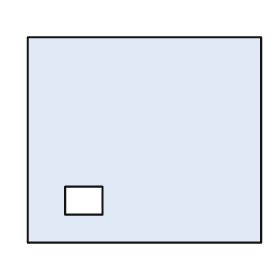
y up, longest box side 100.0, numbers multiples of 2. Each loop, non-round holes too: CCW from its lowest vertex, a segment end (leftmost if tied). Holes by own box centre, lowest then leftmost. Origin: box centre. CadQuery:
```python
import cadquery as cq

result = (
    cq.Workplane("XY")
    .moveTo(-50.0, -44.0)
    .lineTo(50.0, -44.0)
    .lineTo(50.0, 44.0)
    .lineTo(-50.0, 44.0)
    .close()
    .moveTo(-34.0, -32.0)
    .lineTo(-18.0, -32.0)
    .lineTo(-18.0, -20.0)
    .lineTo(-34.0, -20.0)
    .close()
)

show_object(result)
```